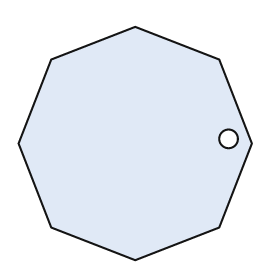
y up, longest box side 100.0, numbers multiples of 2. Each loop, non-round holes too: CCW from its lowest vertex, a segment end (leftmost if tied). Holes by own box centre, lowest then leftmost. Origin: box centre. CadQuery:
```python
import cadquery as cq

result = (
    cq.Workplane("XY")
    .moveTo(0.0, -50.0)
    .lineTo(36.0, -36.0)
    .lineTo(50.0, 0.0)
    .lineTo(36.0, 36.0)
    .lineTo(0.0, 50.0)
    .lineTo(-36.0, 36.0)
    .lineTo(-50.0, 0.0)
    .lineTo(-36.0, -36.0)
    .close()
    .moveTo(40.0, 2.0)
    .circle(4.0)
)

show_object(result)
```